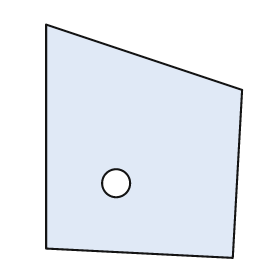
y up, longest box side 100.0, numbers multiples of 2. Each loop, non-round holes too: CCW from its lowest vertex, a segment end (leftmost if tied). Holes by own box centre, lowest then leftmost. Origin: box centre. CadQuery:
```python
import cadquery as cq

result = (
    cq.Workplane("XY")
    .moveTo(38.0, -50.0)
    .lineTo(42.0, 22.0)
    .lineTo(-42.0, 50.0)
    .lineTo(-42.0, -46.0)
    .close()
    .moveTo(-12.0, -18.0)
    .circle(6.0)
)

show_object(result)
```